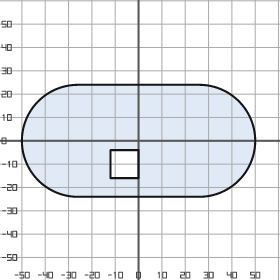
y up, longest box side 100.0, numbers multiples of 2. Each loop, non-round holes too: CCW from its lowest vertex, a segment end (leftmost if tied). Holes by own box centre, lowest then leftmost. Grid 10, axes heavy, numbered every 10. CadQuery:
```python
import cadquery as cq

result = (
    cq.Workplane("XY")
    .moveTo(-26.0, -24.0)
    .lineTo(26.0, -24.0)
    .threePointArc((50.0, 0.0), (26.0, 24.0))
    .lineTo(-26.0, 24.0)
    .threePointArc((-50.0, 0.0), (-26.0, -24.0))
    .close()
    .moveTo(-12.0, -16.0)
    .lineTo(0.0, -16.0)
    .lineTo(0.0, -4.0)
    .lineTo(-12.0, -4.0)
    .close()
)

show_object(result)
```